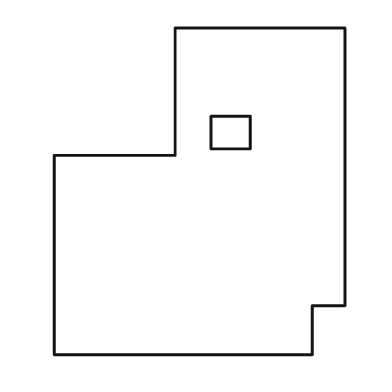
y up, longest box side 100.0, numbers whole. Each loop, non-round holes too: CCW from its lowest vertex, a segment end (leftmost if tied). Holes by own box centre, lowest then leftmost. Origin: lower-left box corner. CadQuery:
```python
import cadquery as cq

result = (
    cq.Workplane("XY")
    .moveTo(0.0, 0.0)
    .lineTo(79.0, 0.0)
    .lineTo(79.0, 15.0)
    .lineTo(89.0, 15.0)
    .lineTo(89.0, 100.0)
    .lineTo(37.0, 100.0)
    .lineTo(37.0, 61.0)
    .lineTo(0.0, 61.0)
    .close()
    .moveTo(48.0, 63.0)
    .lineTo(60.0, 63.0)
    .lineTo(60.0, 73.0)
    .lineTo(48.0, 73.0)
    .close()
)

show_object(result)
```